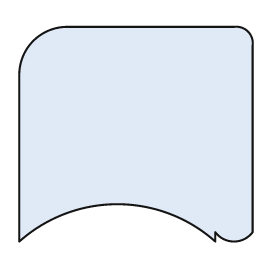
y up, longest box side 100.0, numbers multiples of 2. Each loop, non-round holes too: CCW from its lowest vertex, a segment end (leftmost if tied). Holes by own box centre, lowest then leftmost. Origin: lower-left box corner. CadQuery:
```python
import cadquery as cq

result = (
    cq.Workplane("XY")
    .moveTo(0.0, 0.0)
    .threePointArc((42.0, 16.0), (84.0, 0.0))
    .lineTo(84.0, 4.0)
    .threePointArc((92.0, 0.0), (100.0, 4.0))
    .lineTo(100.0, 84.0)
    .threePointArc((98.0, 90.0), (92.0, 92.0))
    .lineTo(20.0, 92.0)
    .threePointArc((6.0, 86.0), (0.0, 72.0))
    .close()
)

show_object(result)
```